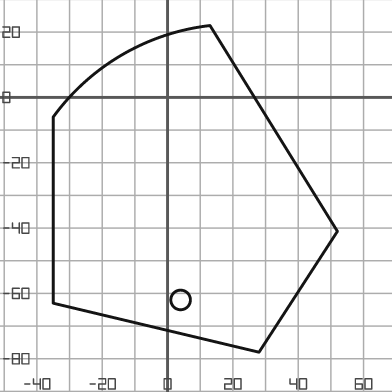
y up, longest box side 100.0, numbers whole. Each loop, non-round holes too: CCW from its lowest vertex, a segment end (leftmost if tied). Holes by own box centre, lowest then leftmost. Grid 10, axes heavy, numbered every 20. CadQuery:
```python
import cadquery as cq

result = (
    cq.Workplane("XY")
    .moveTo(28.0, -78.0)
    .lineTo(52.0, -41.0)
    .lineTo(13.0, 22.0)
    .threePointArc((-14.0, 13.0), (-35.0, -6.0))
    .lineTo(-35.0, -63.0)
    .close()
    .moveTo(4.0, -62.0)
    .circle(3.0)
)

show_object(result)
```